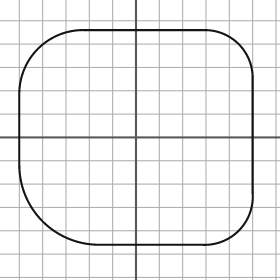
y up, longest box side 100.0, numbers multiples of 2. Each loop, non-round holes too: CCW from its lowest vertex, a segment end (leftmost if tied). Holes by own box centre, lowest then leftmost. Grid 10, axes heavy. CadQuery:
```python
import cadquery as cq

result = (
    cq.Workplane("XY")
    .moveTo(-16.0, -46.0)
    .lineTo(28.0, -46.0)
    .threePointArc((44.0, -40.0), (50.0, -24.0))
    .lineTo(50.0, 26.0)
    .threePointArc((44.0, 40.0), (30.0, 46.0))
    .lineTo(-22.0, 46.0)
    .threePointArc((-42.0, 38.0), (-50.0, 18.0))
    .lineTo(-50.0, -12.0)
    .threePointArc((-40.0, -36.0), (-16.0, -46.0))
    .close()
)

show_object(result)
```